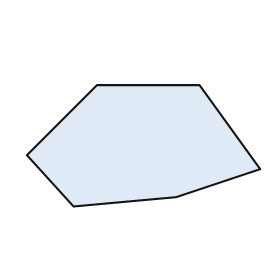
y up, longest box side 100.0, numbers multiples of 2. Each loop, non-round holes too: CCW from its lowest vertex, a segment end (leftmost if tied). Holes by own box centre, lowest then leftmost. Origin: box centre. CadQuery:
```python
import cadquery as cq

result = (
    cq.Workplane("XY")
    .moveTo(-30.0, -26.0)
    .lineTo(14.0, -22.0)
    .lineTo(50.0, -10.0)
    .lineTo(24.0, 26.0)
    .lineTo(-20.0, 26.0)
    .lineTo(-50.0, -4.0)
    .close()
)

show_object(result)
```